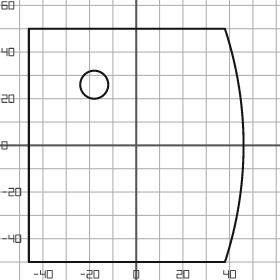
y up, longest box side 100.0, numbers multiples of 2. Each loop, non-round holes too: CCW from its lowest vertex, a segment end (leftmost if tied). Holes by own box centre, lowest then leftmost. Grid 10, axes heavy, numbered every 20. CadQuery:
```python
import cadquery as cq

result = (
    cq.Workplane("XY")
    .moveTo(-46.0, -50.0)
    .lineTo(38.0, -50.0)
    .threePointArc((46.0, 0.0), (38.0, 50.0))
    .lineTo(-46.0, 50.0)
    .close()
    .moveTo(-18.0, 26.0)
    .circle(6.0)
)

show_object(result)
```